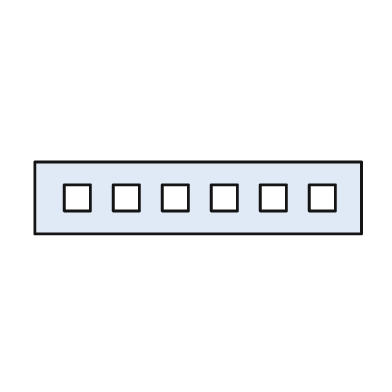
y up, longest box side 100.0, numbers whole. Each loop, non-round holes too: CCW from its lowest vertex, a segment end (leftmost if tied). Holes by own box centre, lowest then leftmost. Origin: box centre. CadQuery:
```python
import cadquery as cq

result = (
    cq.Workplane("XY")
    .moveTo(-50.0, -11.0)
    .lineTo(50.0, -11.0)
    .lineTo(50.0, 11.0)
    .lineTo(-50.0, 11.0)
    .close()
    .moveTo(-41.0, -4.0)
    .lineTo(-33.0, -4.0)
    .lineTo(-33.0, 4.0)
    .lineTo(-41.0, 4.0)
    .close()
    .moveTo(-26.0, -4.0)
    .lineTo(-18.0, -4.0)
    .lineTo(-18.0, 4.0)
    .lineTo(-26.0, 4.0)
    .close()
    .moveTo(-11.0, -4.0)
    .lineTo(-3.0, -4.0)
    .lineTo(-3.0, 4.0)
    .lineTo(-11.0, 4.0)
    .close()
    .moveTo(4.0, -4.0)
    .lineTo(12.0, -4.0)
    .lineTo(12.0, 4.0)
    .lineTo(4.0, 4.0)
    .close()
    .moveTo(19.0, -4.0)
    .lineTo(27.0, -4.0)
    .lineTo(27.0, 4.0)
    .lineTo(19.0, 4.0)
    .close()
    .moveTo(34.0, -4.0)
    .lineTo(42.0, -4.0)
    .lineTo(42.0, 4.0)
    .lineTo(34.0, 4.0)
    .close()
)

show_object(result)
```